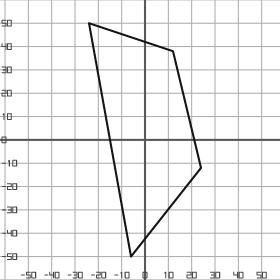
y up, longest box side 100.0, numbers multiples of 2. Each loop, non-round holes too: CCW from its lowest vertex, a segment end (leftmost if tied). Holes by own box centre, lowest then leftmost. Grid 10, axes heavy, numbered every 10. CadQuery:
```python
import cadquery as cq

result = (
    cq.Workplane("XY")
    .moveTo(-6.0, -50.0)
    .lineTo(24.0, -12.0)
    .lineTo(12.0, 38.0)
    .lineTo(-24.0, 50.0)
    .close()
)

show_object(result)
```